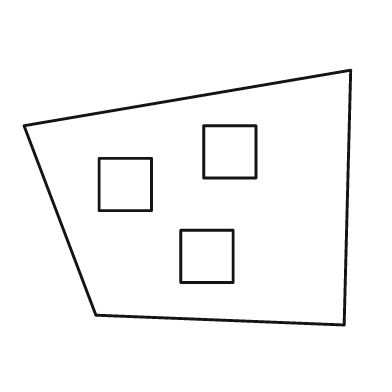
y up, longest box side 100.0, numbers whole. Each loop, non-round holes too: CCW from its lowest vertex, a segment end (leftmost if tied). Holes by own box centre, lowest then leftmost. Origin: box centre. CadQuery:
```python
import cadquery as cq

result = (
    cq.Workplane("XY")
    .moveTo(48.0, -39.0)
    .lineTo(50.0, 39.0)
    .lineTo(-50.0, 22.0)
    .lineTo(-28.0, -36.0)
    .close()
    .moveTo(-2.0, -26.0)
    .lineTo(14.0, -26.0)
    .lineTo(14.0, -10.0)
    .lineTo(-2.0, -10.0)
    .close()
    .moveTo(-27.0, -4.0)
    .lineTo(-11.0, -4.0)
    .lineTo(-11.0, 12.0)
    .lineTo(-27.0, 12.0)
    .close()
    .moveTo(5.0, 6.0)
    .lineTo(21.0, 6.0)
    .lineTo(21.0, 22.0)
    .lineTo(5.0, 22.0)
    .close()
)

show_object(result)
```